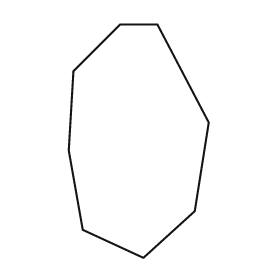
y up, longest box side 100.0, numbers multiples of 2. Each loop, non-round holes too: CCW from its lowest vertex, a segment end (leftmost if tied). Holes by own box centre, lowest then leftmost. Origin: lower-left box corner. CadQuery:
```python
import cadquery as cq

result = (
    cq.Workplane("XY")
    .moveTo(32.0, 0.0)
    .lineTo(54.0, 20.0)
    .lineTo(60.0, 58.0)
    .lineTo(38.0, 100.0)
    .lineTo(22.0, 100.0)
    .lineTo(2.0, 80.0)
    .lineTo(0.0, 46.0)
    .lineTo(6.0, 12.0)
    .close()
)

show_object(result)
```